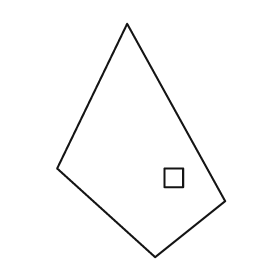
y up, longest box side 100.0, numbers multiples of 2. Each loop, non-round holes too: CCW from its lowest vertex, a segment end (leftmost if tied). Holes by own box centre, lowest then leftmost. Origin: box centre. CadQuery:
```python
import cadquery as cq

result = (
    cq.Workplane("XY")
    .moveTo(6.0, -50.0)
    .lineTo(36.0, -26.0)
    .lineTo(-6.0, 50.0)
    .lineTo(-36.0, -12.0)
    .close()
    .moveTo(10.0, -20.0)
    .lineTo(18.0, -20.0)
    .lineTo(18.0, -12.0)
    .lineTo(10.0, -12.0)
    .close()
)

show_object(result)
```